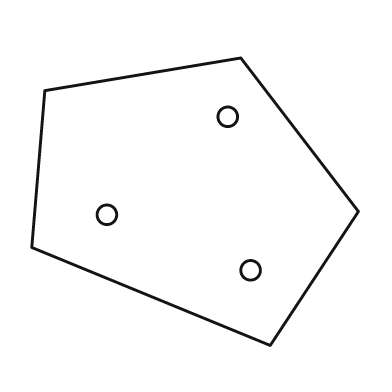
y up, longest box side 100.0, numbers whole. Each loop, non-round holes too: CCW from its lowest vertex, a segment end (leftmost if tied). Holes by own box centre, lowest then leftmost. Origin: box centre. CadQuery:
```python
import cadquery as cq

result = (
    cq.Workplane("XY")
    .moveTo(23.0, -44.0)
    .lineTo(50.0, -3.0)
    .lineTo(14.0, 44.0)
    .lineTo(-46.0, 34.0)
    .lineTo(-50.0, -14.0)
    .close()
    .moveTo(17.0, -21.0)
    .circle(3.0)
    .moveTo(-27.0, -4.0)
    .circle(3.0)
    .moveTo(10.0, 26.0)
    .circle(3.0)
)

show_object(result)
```